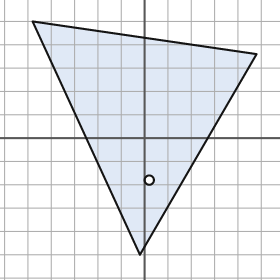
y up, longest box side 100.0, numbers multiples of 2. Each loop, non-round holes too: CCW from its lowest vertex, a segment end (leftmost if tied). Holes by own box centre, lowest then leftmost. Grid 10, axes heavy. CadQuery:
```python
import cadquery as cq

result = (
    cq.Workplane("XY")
    .moveTo(-2.0, -50.0)
    .lineTo(48.0, 36.0)
    .lineTo(-48.0, 50.0)
    .close()
    .moveTo(2.0, -18.0)
    .circle(2.0)
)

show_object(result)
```